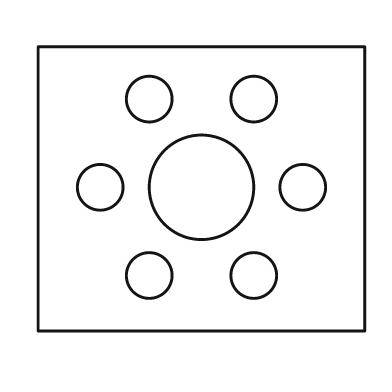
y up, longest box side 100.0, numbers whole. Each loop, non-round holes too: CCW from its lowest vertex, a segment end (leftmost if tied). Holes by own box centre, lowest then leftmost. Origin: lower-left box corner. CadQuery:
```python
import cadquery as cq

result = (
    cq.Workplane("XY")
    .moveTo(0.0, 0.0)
    .lineTo(100.0, 0.0)
    .lineTo(100.0, 87.0)
    .lineTo(0.0, 87.0)
    .close()
    .moveTo(34.0, 17.0)
    .circle(7.0)
    .moveTo(66.0, 17.0)
    .circle(7.0)
    .moveTo(19.0, 44.0)
    .circle(7.0)
    .moveTo(50.0, 44.0)
    .circle(16.0)
    .moveTo(81.0, 44.0)
    .circle(7.0)
    .moveTo(34.0, 71.0)
    .circle(7.0)
    .moveTo(66.0, 71.0)
    .circle(7.0)
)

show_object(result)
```